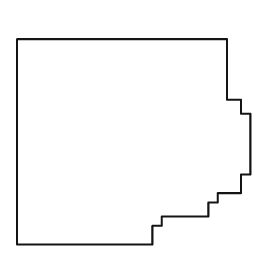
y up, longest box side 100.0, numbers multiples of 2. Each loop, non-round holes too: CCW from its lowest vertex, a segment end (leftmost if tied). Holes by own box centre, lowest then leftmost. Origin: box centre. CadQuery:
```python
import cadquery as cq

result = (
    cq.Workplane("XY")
    .moveTo(-50.0, -44.0)
    .lineTo(8.0, -44.0)
    .lineTo(8.0, -36.0)
    .lineTo(12.0, -36.0)
    .lineTo(12.0, -32.0)
    .lineTo(32.0, -32.0)
    .lineTo(32.0, -26.0)
    .lineTo(36.0, -26.0)
    .lineTo(36.0, -22.0)
    .lineTo(46.0, -22.0)
    .lineTo(46.0, -14.0)
    .lineTo(50.0, -14.0)
    .lineTo(50.0, 12.0)
    .lineTo(46.0, 12.0)
    .lineTo(46.0, 18.0)
    .lineTo(40.0, 18.0)
    .lineTo(40.0, 44.0)
    .lineTo(-50.0, 44.0)
    .close()
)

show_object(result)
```